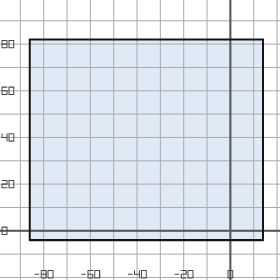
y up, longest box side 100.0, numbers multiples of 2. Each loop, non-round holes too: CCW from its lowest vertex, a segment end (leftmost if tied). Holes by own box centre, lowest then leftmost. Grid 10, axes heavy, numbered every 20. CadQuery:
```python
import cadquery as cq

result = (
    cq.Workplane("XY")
    .moveTo(-86.0, -4.0)
    .lineTo(14.0, -4.0)
    .lineTo(14.0, 82.0)
    .lineTo(-86.0, 82.0)
    .close()
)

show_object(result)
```